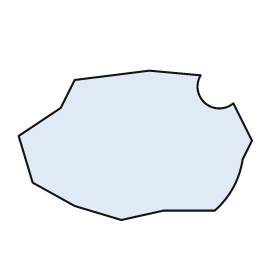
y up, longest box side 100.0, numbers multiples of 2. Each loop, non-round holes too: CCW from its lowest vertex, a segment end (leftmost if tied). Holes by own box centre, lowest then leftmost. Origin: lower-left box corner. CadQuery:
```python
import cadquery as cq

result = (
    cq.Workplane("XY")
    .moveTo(44.0, 0.0)
    .lineTo(62.0, 4.0)
    .lineTo(84.0, 4.0)
    .threePointArc((92.0, 14.0), (96.0, 26.0))
    .lineTo(100.0, 34.0)
    .lineTo(92.0, 50.0)
    .threePointArc((80.0, 50.0), (78.0, 62.0))
    .lineTo(56.0, 64.0)
    .lineTo(24.0, 60.0)
    .lineTo(18.0, 48.0)
    .lineTo(0.0, 36.0)
    .lineTo(6.0, 16.0)
    .lineTo(24.0, 6.0)
    .close()
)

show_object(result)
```